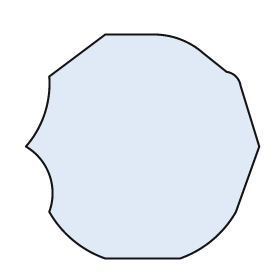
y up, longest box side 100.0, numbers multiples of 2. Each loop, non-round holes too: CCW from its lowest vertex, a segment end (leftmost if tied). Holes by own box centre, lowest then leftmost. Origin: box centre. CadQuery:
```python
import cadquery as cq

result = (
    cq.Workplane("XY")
    .moveTo(-16.0, -48.0)
    .lineTo(16.0, -48.0)
    .threePointArc((30.0, -40.0), (40.0, -28.0))
    .lineTo(50.0, 0.0)
    .lineTo(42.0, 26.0)
    .threePointArc((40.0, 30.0), (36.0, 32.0))
    .lineTo(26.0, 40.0)
    .threePointArc((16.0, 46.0), (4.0, 48.0))
    .lineTo(-16.0, 48.0)
    .lineTo(-40.0, 30.0)
    .threePointArc((-42.0, 14.0), (-50.0, 0.0))
    .threePointArc((-40.0, -12.0), (-40.0, -28.0))
    .threePointArc((-30.0, -40.0), (-16.0, -48.0))
    .close()
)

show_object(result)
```